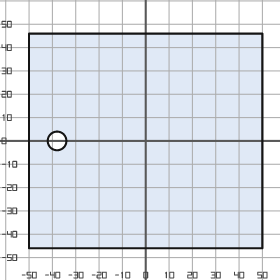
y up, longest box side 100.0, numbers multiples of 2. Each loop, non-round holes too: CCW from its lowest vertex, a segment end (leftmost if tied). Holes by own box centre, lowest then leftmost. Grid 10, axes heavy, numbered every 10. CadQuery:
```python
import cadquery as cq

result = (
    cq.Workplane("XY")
    .moveTo(-50.0, -46.0)
    .lineTo(50.0, -46.0)
    .lineTo(50.0, 46.0)
    .lineTo(-50.0, 46.0)
    .close()
    .moveTo(-38.0, 0.0)
    .circle(4.0)
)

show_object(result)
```